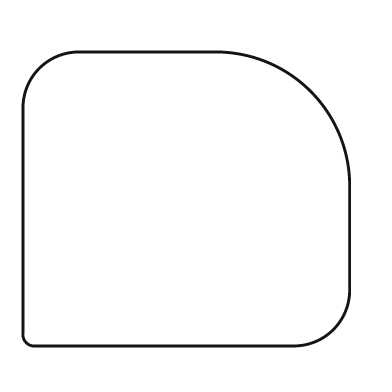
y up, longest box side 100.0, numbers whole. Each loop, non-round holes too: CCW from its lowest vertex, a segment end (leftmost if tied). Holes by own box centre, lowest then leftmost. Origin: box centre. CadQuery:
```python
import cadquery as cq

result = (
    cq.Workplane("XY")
    .moveTo(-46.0, -45.0)
    .lineTo(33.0, -45.0)
    .threePointArc((45.0, -40.0), (50.0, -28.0))
    .lineTo(50.0, 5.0)
    .threePointArc((38.0, 33.0), (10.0, 45.0))
    .lineTo(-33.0, 45.0)
    .threePointArc((-45.0, 40.0), (-50.0, 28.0))
    .lineTo(-50.0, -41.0)
    .threePointArc((-49.0, -44.0), (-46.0, -45.0))
    .close()
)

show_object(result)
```